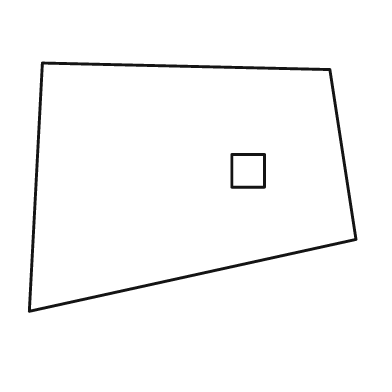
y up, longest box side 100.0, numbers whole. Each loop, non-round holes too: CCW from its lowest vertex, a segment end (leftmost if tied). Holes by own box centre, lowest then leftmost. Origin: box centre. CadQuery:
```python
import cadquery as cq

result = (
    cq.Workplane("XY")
    .moveTo(-50.0, -38.0)
    .lineTo(50.0, -16.0)
    .lineTo(42.0, 36.0)
    .lineTo(-46.0, 38.0)
    .close()
    .moveTo(12.0, 0.0)
    .lineTo(22.0, 0.0)
    .lineTo(22.0, 10.0)
    .lineTo(12.0, 10.0)
    .close()
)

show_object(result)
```